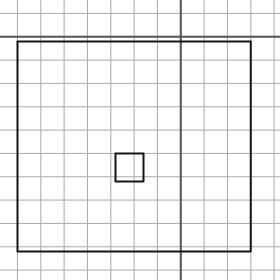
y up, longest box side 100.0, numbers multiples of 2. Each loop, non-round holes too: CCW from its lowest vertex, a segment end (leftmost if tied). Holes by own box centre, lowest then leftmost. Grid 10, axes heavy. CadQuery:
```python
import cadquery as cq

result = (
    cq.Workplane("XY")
    .moveTo(-70.0, -92.0)
    .lineTo(30.0, -92.0)
    .lineTo(30.0, -2.0)
    .lineTo(-70.0, -2.0)
    .close()
    .moveTo(-28.0, -62.0)
    .lineTo(-16.0, -62.0)
    .lineTo(-16.0, -50.0)
    .lineTo(-28.0, -50.0)
    .close()
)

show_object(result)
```